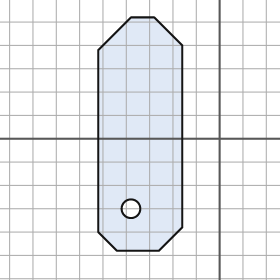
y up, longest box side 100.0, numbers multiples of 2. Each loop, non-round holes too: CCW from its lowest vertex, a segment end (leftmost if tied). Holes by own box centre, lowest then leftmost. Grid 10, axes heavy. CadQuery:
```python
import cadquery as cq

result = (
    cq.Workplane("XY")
    .moveTo(-44.0, -48.0)
    .lineTo(-26.0, -48.0)
    .lineTo(-16.0, -38.0)
    .lineTo(-16.0, 40.0)
    .lineTo(-28.0, 52.0)
    .lineTo(-38.0, 52.0)
    .lineTo(-52.0, 38.0)
    .lineTo(-52.0, -40.0)
    .close()
    .moveTo(-38.0, -30.0)
    .circle(4.0)
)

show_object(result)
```